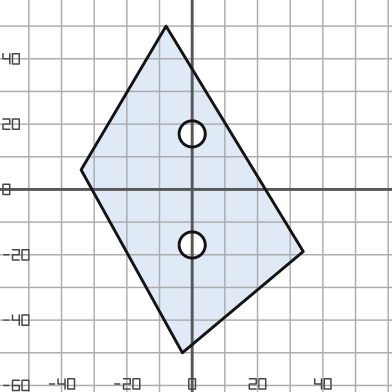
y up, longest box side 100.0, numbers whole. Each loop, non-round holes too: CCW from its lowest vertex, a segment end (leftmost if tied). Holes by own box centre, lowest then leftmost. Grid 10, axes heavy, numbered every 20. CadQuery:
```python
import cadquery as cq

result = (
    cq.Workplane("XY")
    .moveTo(-3.0, -50.0)
    .lineTo(34.0, -19.0)
    .lineTo(-8.0, 50.0)
    .lineTo(-34.0, 6.0)
    .close()
    .moveTo(0.0, -17.0)
    .circle(4.0)
    .moveTo(0.0, 17.0)
    .circle(4.0)
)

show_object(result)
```